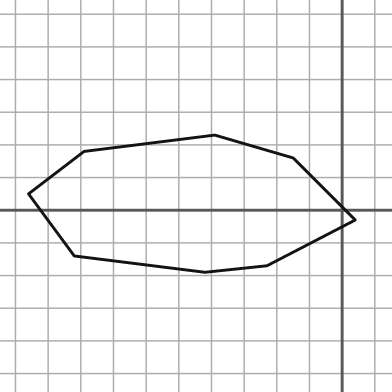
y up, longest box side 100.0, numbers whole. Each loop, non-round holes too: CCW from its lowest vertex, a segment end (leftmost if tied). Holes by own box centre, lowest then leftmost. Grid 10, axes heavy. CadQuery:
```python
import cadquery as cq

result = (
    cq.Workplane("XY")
    .moveTo(-42.0, -19.0)
    .lineTo(-23.0, -17.0)
    .lineTo(4.0, -3.0)
    .lineTo(-15.0, 16.0)
    .lineTo(-39.0, 23.0)
    .lineTo(-79.0, 18.0)
    .lineTo(-96.0, 5.0)
    .lineTo(-82.0, -14.0)
    .close()
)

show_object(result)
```